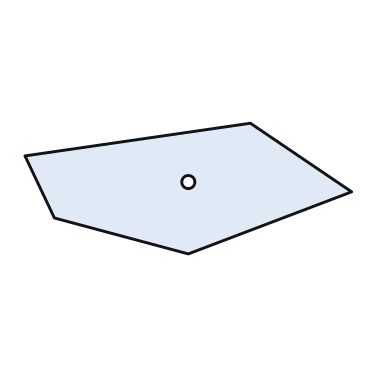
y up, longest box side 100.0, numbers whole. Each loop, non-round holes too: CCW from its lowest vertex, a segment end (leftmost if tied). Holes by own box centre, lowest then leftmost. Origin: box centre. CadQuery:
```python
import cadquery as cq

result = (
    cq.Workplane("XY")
    .moveTo(0.0, -20.0)
    .lineTo(50.0, -1.0)
    .lineTo(19.0, 20.0)
    .lineTo(-50.0, 10.0)
    .lineTo(-41.0, -9.0)
    .close()
    .moveTo(0.0, 2.0)
    .circle(2.0)
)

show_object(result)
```